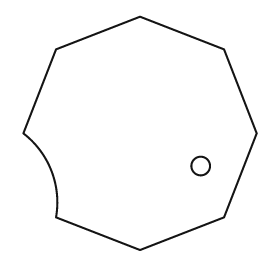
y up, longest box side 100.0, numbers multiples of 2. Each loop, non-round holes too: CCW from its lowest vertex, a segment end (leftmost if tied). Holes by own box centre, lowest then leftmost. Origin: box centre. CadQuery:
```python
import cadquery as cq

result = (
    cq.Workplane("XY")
    .moveTo(0.0, -50.0)
    .lineTo(36.0, -36.0)
    .lineTo(50.0, 0.0)
    .lineTo(36.0, 36.0)
    .lineTo(0.0, 50.0)
    .lineTo(-36.0, 36.0)
    .lineTo(-50.0, 0.0)
    .threePointArc((-38.0, -16.0), (-36.0, -36.0))
    .close()
    .moveTo(26.0, -14.0)
    .circle(4.0)
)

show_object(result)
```